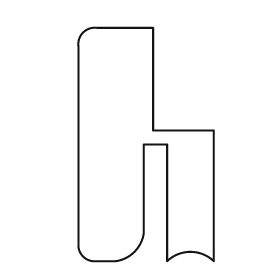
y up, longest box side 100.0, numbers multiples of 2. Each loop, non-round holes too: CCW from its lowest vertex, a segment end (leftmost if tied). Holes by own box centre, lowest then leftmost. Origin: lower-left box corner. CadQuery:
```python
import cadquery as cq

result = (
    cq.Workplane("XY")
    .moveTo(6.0, 0.0)
    .lineTo(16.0, 0.0)
    .threePointArc((24.0, 4.0), (28.0, 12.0))
    .lineTo(28.0, 50.0)
    .lineTo(38.0, 50.0)
    .lineTo(38.0, 0.0)
    .threePointArc((48.0, 4.0), (58.0, 0.0))
    .lineTo(58.0, 56.0)
    .lineTo(32.0, 56.0)
    .lineTo(32.0, 100.0)
    .lineTo(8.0, 100.0)
    .threePointArc((2.0, 98.0), (0.0, 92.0))
    .lineTo(0.0, 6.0)
    .threePointArc((2.0, 2.0), (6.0, 0.0))
    .close()
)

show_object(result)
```